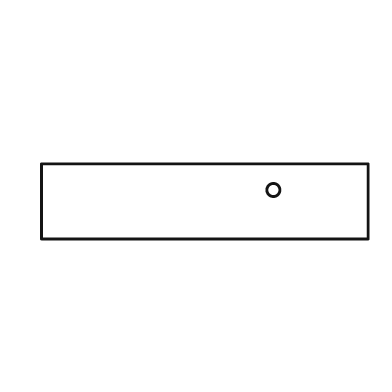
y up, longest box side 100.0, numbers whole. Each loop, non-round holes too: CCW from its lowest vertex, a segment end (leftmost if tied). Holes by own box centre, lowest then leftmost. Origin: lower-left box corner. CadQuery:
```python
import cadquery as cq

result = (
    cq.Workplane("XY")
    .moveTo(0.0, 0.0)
    .lineTo(100.0, 0.0)
    .lineTo(100.0, 23.0)
    .lineTo(0.0, 23.0)
    .close()
    .moveTo(71.0, 15.0)
    .circle(2.0)
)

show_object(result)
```